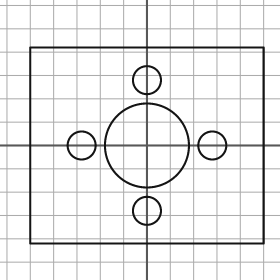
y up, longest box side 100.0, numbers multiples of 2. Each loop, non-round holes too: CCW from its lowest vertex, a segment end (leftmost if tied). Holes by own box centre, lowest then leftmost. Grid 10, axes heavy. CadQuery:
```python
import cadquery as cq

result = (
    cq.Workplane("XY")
    .moveTo(-50.0, -42.0)
    .lineTo(50.0, -42.0)
    .lineTo(50.0, 42.0)
    .lineTo(-50.0, 42.0)
    .close()
    .moveTo(0.0, -28.0)
    .circle(6.0)
    .moveTo(-28.0, 0.0)
    .circle(6.0)
    .moveTo(0.0, 0.0)
    .circle(18.0)
    .moveTo(28.0, 0.0)
    .circle(6.0)
    .moveTo(0.0, 28.0)
    .circle(6.0)
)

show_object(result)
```